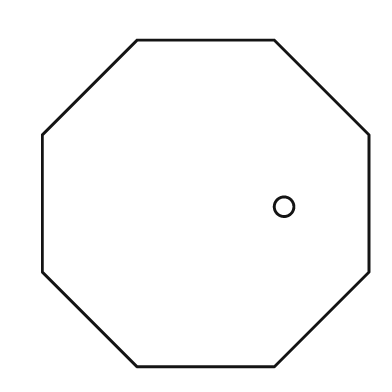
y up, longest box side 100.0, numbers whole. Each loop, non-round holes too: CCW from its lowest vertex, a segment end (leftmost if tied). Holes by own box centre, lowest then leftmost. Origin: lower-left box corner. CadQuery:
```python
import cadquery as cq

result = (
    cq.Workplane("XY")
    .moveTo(29.0, 0.0)
    .lineTo(71.0, 0.0)
    .lineTo(100.0, 29.0)
    .lineTo(100.0, 71.0)
    .lineTo(71.0, 100.0)
    .lineTo(29.0, 100.0)
    .lineTo(0.0, 71.0)
    .lineTo(0.0, 29.0)
    .close()
    .moveTo(74.0, 49.0)
    .circle(3.0)
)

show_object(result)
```